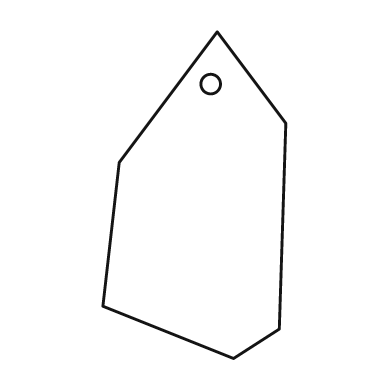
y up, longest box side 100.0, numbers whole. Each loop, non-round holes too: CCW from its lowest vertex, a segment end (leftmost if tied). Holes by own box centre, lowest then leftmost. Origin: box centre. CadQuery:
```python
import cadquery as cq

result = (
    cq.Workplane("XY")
    .moveTo(12.0, -50.0)
    .lineTo(26.0, -41.0)
    .lineTo(28.0, 22.0)
    .lineTo(7.0, 50.0)
    .lineTo(-23.0, 10.0)
    .lineTo(-28.0, -34.0)
    .close()
    .moveTo(5.0, 34.0)
    .circle(3.0)
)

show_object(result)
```